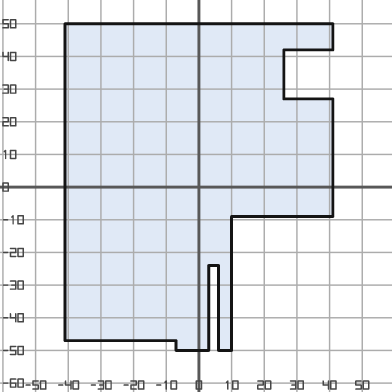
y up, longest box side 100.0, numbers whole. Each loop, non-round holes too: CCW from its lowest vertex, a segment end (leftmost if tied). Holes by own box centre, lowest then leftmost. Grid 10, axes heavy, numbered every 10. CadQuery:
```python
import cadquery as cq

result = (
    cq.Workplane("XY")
    .moveTo(-7.0, -50.0)
    .lineTo(3.0, -50.0)
    .lineTo(3.0, -24.0)
    .lineTo(6.0, -24.0)
    .lineTo(6.0, -50.0)
    .lineTo(10.0, -50.0)
    .lineTo(10.0, -9.0)
    .lineTo(41.0, -9.0)
    .lineTo(41.0, 27.0)
    .lineTo(26.0, 27.0)
    .lineTo(26.0, 42.0)
    .lineTo(41.0, 42.0)
    .lineTo(41.0, 50.0)
    .lineTo(-41.0, 50.0)
    .lineTo(-41.0, -47.0)
    .lineTo(-7.0, -47.0)
    .close()
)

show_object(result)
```